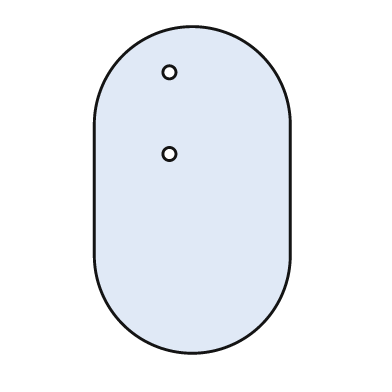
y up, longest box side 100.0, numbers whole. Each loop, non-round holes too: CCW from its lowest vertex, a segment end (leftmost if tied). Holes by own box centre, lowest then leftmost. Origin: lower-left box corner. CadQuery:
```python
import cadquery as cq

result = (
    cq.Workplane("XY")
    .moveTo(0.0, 30.0)
    .threePointArc((30.0, 0.0), (60.0, 30.0))
    .lineTo(60.0, 70.0)
    .threePointArc((30.0, 100.0), (0.0, 70.0))
    .close()
    .moveTo(23.0, 61.0)
    .circle(2.0)
    .moveTo(23.0, 86.0)
    .circle(2.0)
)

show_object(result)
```